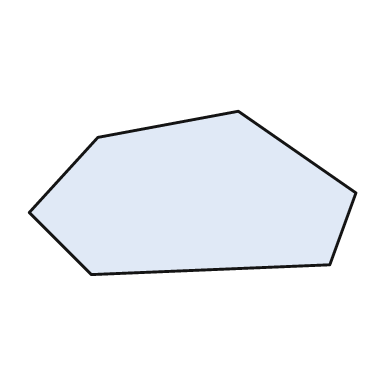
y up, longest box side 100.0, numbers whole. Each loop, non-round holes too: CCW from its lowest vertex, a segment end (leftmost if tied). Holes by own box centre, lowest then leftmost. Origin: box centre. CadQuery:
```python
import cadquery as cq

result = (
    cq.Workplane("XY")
    .moveTo(-31.0, -25.0)
    .lineTo(42.0, -22.0)
    .lineTo(50.0, 0.0)
    .lineTo(14.0, 25.0)
    .lineTo(-29.0, 17.0)
    .lineTo(-50.0, -6.0)
    .close()
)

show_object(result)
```